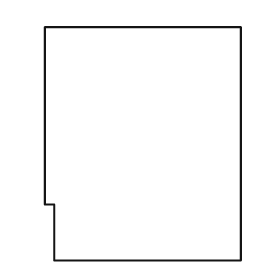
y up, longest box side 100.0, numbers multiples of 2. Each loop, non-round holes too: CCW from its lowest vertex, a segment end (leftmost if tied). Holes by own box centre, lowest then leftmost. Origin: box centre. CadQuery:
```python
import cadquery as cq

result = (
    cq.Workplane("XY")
    .moveTo(-38.0, -50.0)
    .lineTo(42.0, -50.0)
    .lineTo(42.0, 50.0)
    .lineTo(-42.0, 50.0)
    .lineTo(-42.0, -26.0)
    .lineTo(-38.0, -26.0)
    .close()
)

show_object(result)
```